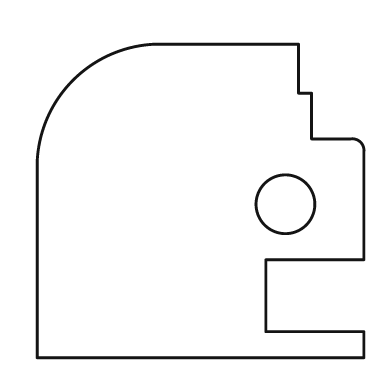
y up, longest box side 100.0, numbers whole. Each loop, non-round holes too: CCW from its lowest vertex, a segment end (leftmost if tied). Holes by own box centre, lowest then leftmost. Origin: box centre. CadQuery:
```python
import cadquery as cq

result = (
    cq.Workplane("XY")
    .moveTo(-50.0, -48.0)
    .lineTo(50.0, -48.0)
    .lineTo(50.0, -40.0)
    .lineTo(20.0, -40.0)
    .lineTo(20.0, -18.0)
    .lineTo(50.0, -18.0)
    .lineTo(50.0, 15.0)
    .threePointArc((49.0, 18.0), (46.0, 19.0))
    .lineTo(34.0, 19.0)
    .lineTo(34.0, 33.0)
    .lineTo(30.0, 33.0)
    .lineTo(30.0, 48.0)
    .lineTo(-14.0, 48.0)
    .threePointArc((-39.0, 37.0), (-50.0, 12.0))
    .close()
    .moveTo(26.0, -1.0)
    .circle(9.0)
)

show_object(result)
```